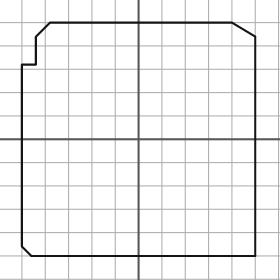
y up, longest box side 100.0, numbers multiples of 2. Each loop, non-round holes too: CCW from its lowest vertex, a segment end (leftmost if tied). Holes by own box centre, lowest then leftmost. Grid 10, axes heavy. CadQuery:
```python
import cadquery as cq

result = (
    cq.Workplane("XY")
    .moveTo(-46.0, -50.0)
    .lineTo(50.0, -50.0)
    .lineTo(50.0, 44.0)
    .lineTo(40.0, 50.0)
    .lineTo(-38.0, 50.0)
    .lineTo(-44.0, 44.0)
    .lineTo(-44.0, 32.0)
    .lineTo(-50.0, 32.0)
    .lineTo(-50.0, -46.0)
    .close()
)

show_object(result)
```